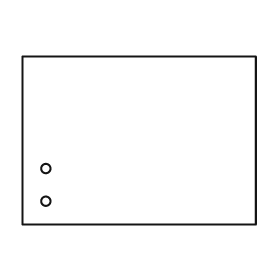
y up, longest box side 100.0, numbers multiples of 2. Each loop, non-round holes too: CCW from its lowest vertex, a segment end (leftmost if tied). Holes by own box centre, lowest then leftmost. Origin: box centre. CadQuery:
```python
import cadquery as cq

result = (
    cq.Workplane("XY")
    .moveTo(-50.0, -36.0)
    .lineTo(50.0, -36.0)
    .lineTo(50.0, 36.0)
    .lineTo(-50.0, 36.0)
    .close()
    .moveTo(-40.0, -26.0)
    .circle(2.0)
    .moveTo(-40.0, -12.0)
    .circle(2.0)
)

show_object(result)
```